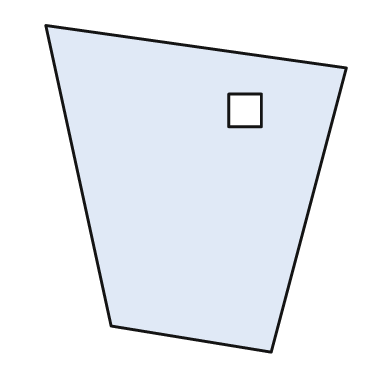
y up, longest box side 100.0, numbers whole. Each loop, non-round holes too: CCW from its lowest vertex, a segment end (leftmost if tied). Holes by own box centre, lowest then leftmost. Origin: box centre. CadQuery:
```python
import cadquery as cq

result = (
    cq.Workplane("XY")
    .moveTo(23.0, -50.0)
    .lineTo(46.0, 37.0)
    .lineTo(-46.0, 50.0)
    .lineTo(-26.0, -42.0)
    .close()
    .moveTo(10.0, 19.0)
    .lineTo(20.0, 19.0)
    .lineTo(20.0, 29.0)
    .lineTo(10.0, 29.0)
    .close()
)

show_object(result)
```